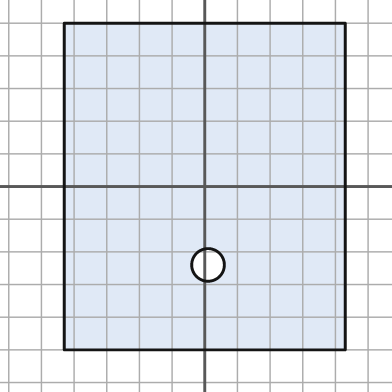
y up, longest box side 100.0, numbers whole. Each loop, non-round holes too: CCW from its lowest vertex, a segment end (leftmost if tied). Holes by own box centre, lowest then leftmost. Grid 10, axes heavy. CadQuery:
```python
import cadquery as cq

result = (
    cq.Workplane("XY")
    .moveTo(-43.0, -50.0)
    .lineTo(43.0, -50.0)
    .lineTo(43.0, 50.0)
    .lineTo(-43.0, 50.0)
    .close()
    .moveTo(1.0, -24.0)
    .circle(5.0)
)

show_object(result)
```